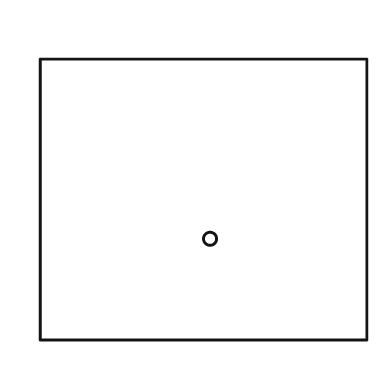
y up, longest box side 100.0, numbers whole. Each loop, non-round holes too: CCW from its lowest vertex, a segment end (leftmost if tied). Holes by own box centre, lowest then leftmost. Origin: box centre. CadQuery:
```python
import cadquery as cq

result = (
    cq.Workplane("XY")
    .moveTo(-50.0, -43.0)
    .lineTo(50.0, -43.0)
    .lineTo(50.0, 43.0)
    .lineTo(-50.0, 43.0)
    .close()
    .moveTo(2.0, -12.0)
    .circle(2.0)
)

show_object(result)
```